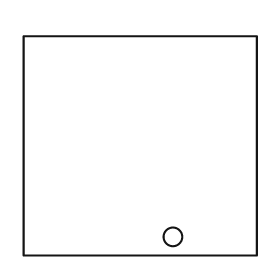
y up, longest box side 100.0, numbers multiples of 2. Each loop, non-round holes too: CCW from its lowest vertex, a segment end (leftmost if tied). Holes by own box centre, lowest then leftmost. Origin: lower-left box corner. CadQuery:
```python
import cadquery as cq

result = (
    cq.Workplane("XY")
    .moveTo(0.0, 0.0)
    .lineTo(100.0, 0.0)
    .lineTo(100.0, 94.0)
    .lineTo(0.0, 94.0)
    .close()
    .moveTo(64.0, 8.0)
    .circle(4.0)
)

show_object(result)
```